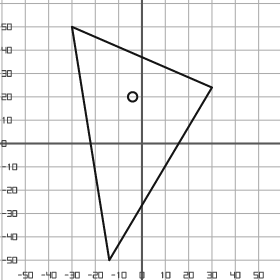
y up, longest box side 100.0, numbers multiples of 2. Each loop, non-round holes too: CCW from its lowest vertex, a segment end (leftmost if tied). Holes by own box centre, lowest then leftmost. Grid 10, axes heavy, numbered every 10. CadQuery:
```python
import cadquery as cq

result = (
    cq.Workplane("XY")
    .moveTo(-14.0, -50.0)
    .lineTo(30.0, 24.0)
    .lineTo(-30.0, 50.0)
    .close()
    .moveTo(-4.0, 20.0)
    .circle(2.0)
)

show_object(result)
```